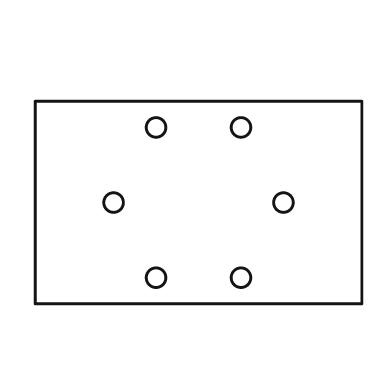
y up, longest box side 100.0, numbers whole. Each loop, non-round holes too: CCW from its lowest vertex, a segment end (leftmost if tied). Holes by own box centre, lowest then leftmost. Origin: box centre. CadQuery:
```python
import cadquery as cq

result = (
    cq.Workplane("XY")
    .moveTo(-50.0, -31.0)
    .lineTo(50.0, -31.0)
    .lineTo(50.0, 31.0)
    .lineTo(-50.0, 31.0)
    .close()
    .moveTo(-13.0, -23.0)
    .circle(3.0)
    .moveTo(13.0, -23.0)
    .circle(3.0)
    .moveTo(-26.0, 0.0)
    .circle(3.0)
    .moveTo(26.0, 0.0)
    .circle(3.0)
    .moveTo(-13.0, 23.0)
    .circle(3.0)
    .moveTo(13.0, 23.0)
    .circle(3.0)
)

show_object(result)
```